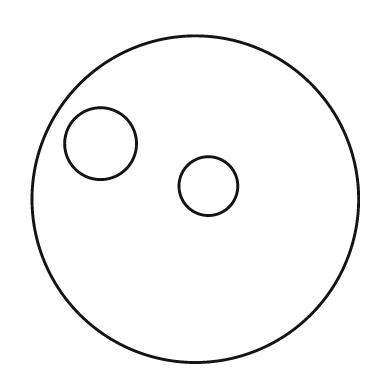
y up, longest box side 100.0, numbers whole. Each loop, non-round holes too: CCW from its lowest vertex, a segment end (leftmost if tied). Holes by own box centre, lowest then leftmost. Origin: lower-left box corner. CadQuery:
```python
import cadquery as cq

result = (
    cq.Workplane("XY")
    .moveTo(50.0, 50.0)
    .circle(50.0)
    .moveTo(54.0, 54.0)
    .circle(9.0)
    .moveTo(21.0, 67.0)
    .circle(11.0)
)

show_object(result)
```